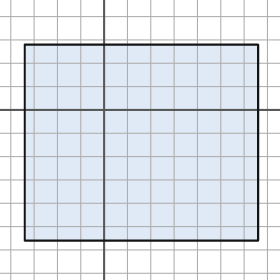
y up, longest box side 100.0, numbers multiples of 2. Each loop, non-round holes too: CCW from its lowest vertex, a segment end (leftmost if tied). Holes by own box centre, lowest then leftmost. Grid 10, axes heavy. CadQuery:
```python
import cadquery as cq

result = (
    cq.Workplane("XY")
    .moveTo(-34.0, -56.0)
    .lineTo(66.0, -56.0)
    .lineTo(66.0, 28.0)
    .lineTo(-34.0, 28.0)
    .close()
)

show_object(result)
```